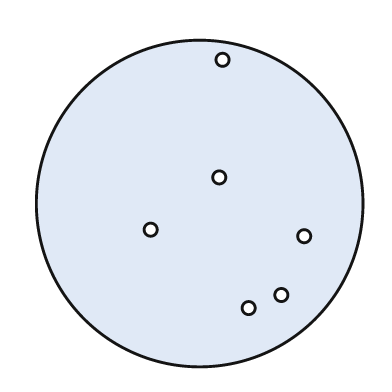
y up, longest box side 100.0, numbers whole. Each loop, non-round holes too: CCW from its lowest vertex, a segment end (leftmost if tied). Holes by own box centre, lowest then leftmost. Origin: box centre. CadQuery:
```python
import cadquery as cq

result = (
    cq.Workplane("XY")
    .moveTo(0.0, 0.0)
    .circle(50.0)
    .moveTo(15.0, -32.0)
    .circle(2.0)
    .moveTo(25.0, -28.0)
    .circle(2.0)
    .moveTo(32.0, -10.0)
    .circle(2.0)
    .moveTo(-15.0, -8.0)
    .circle(2.0)
    .moveTo(6.0, 8.0)
    .circle(2.0)
    .moveTo(7.0, 44.0)
    .circle(2.0)
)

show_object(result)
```